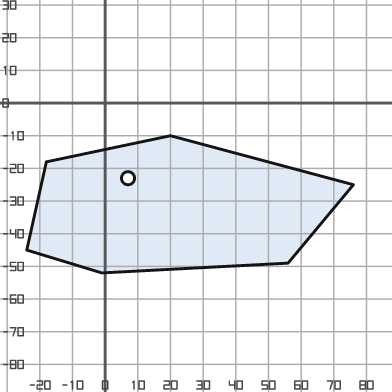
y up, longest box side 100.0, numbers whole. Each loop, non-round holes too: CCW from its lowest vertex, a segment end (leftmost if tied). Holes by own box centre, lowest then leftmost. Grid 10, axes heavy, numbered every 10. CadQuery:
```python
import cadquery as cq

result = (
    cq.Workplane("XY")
    .moveTo(-1.0, -52.0)
    .lineTo(56.0, -49.0)
    .lineTo(76.0, -25.0)
    .lineTo(20.0, -10.0)
    .lineTo(-18.0, -18.0)
    .lineTo(-24.0, -45.0)
    .close()
    .moveTo(7.0, -23.0)
    .circle(2.0)
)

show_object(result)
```